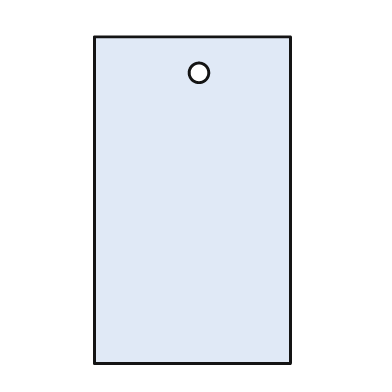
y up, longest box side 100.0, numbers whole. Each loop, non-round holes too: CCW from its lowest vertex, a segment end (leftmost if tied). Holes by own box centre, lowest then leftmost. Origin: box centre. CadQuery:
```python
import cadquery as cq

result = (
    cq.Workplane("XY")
    .moveTo(-30.0, -50.0)
    .lineTo(30.0, -50.0)
    .lineTo(30.0, 50.0)
    .lineTo(-30.0, 50.0)
    .close()
    .moveTo(2.0, 39.0)
    .circle(3.0)
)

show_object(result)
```